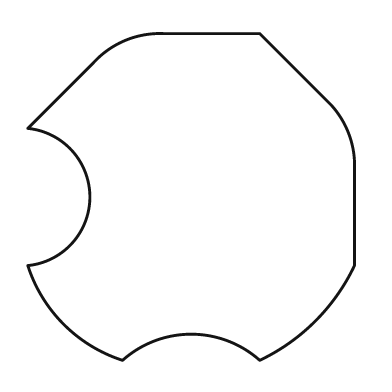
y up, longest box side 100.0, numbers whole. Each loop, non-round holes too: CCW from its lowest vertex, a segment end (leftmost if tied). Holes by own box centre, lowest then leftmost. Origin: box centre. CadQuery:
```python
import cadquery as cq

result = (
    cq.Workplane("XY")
    .moveTo(-21.0, -50.0)
    .threePointArc((0.0, -42.0), (21.0, -50.0))
    .threePointArc((38.0, -38.0), (50.0, -21.0))
    .lineTo(50.0, 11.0)
    .threePointArc((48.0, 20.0), (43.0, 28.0))
    .lineTo(21.0, 50.0)
    .lineTo(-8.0, 50.0)
    .threePointArc((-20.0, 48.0), (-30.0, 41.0))
    .lineTo(-50.0, 21.0)
    .threePointArc((-31.0, 0.0), (-50.0, -21.0))
    .threePointArc((-39.0, -39.0), (-21.0, -50.0))
    .close()
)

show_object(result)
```